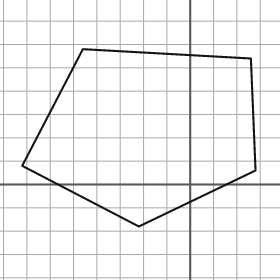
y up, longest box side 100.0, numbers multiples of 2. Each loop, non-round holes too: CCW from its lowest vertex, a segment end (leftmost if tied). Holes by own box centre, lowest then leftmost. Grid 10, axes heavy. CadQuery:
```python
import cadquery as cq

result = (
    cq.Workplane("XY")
    .moveTo(-22.0, -18.0)
    .lineTo(28.0, 6.0)
    .lineTo(26.0, 54.0)
    .lineTo(-46.0, 58.0)
    .lineTo(-72.0, 8.0)
    .close()
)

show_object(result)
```